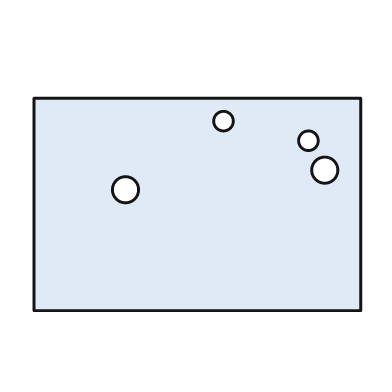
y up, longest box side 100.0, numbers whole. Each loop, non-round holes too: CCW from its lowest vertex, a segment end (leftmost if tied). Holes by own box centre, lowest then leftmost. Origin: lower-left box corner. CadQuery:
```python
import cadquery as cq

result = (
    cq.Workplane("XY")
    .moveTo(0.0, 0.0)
    .lineTo(100.0, 0.0)
    .lineTo(100.0, 65.0)
    .lineTo(0.0, 65.0)
    .close()
    .moveTo(28.0, 37.0)
    .circle(4.0)
    .moveTo(89.0, 43.0)
    .circle(4.0)
    .moveTo(84.0, 52.0)
    .circle(3.0)
    .moveTo(58.0, 58.0)
    .circle(3.0)
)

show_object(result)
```